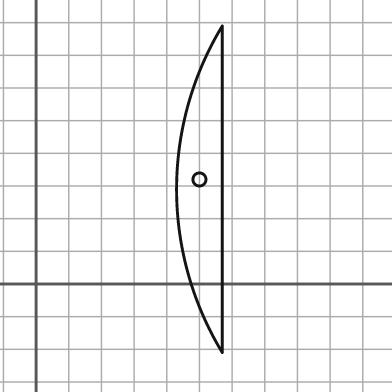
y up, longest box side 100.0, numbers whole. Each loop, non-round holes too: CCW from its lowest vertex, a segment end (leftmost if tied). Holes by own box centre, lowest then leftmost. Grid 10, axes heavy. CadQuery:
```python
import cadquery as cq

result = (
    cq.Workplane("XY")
    .moveTo(57.0, -21.0)
    .lineTo(57.0, 79.0)
    .threePointArc((43.0, 29.0), (57.0, -21.0))
    .close()
    .moveTo(50.0, 32.0)
    .circle(2.0)
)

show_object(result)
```